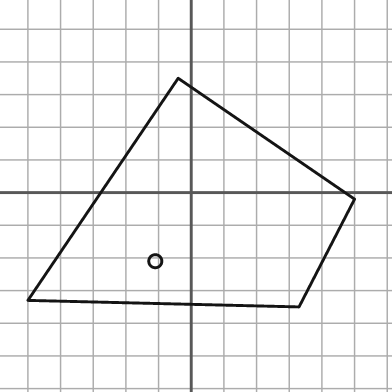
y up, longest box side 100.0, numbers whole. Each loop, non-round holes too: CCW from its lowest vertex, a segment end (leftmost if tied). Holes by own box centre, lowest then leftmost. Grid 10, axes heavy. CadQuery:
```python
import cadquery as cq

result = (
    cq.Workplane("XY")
    .moveTo(33.0, -35.0)
    .lineTo(50.0, -2.0)
    .lineTo(-4.0, 35.0)
    .lineTo(-50.0, -33.0)
    .close()
    .moveTo(-11.0, -21.0)
    .circle(2.0)
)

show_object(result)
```